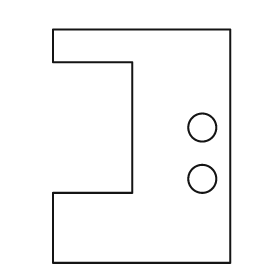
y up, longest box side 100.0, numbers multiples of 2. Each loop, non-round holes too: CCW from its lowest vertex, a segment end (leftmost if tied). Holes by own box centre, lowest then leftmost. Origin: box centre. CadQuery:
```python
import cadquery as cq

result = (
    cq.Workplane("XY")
    .moveTo(-38.0, -50.0)
    .lineTo(38.0, -50.0)
    .lineTo(38.0, 50.0)
    .lineTo(-38.0, 50.0)
    .lineTo(-38.0, 36.0)
    .lineTo(-4.0, 36.0)
    .lineTo(-4.0, -20.0)
    .lineTo(-38.0, -20.0)
    .close()
    .moveTo(26.0, -14.0)
    .circle(6.0)
    .moveTo(26.0, 8.0)
    .circle(6.0)
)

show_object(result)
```